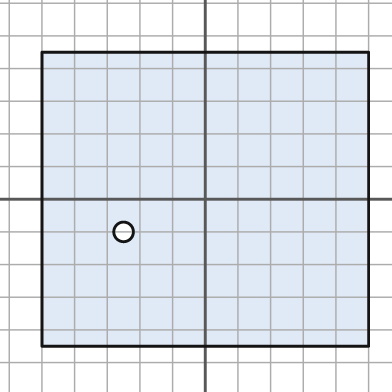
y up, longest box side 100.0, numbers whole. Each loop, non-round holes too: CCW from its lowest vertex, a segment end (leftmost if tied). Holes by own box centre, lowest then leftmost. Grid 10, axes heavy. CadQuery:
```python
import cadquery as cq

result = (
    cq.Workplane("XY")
    .moveTo(-50.0, -45.0)
    .lineTo(50.0, -45.0)
    .lineTo(50.0, 45.0)
    .lineTo(-50.0, 45.0)
    .close()
    .moveTo(-25.0, -10.0)
    .circle(3.0)
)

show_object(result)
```